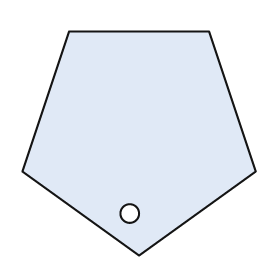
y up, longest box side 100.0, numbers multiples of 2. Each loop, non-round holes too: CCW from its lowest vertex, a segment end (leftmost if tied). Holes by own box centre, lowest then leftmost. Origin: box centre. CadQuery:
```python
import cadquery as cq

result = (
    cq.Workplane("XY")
    .moveTo(0.0, -48.0)
    .lineTo(50.0, -12.0)
    .lineTo(30.0, 48.0)
    .lineTo(-30.0, 48.0)
    .lineTo(-50.0, -12.0)
    .close()
    .moveTo(-4.0, -30.0)
    .circle(4.0)
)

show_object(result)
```